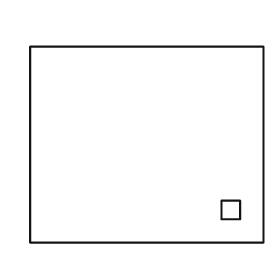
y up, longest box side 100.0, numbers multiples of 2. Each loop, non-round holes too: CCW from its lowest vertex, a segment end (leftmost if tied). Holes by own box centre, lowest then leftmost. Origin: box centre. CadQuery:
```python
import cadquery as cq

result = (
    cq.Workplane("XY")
    .moveTo(-50.0, -42.0)
    .lineTo(50.0, -42.0)
    .lineTo(50.0, 42.0)
    .lineTo(-50.0, 42.0)
    .close()
    .moveTo(32.0, -32.0)
    .lineTo(40.0, -32.0)
    .lineTo(40.0, -24.0)
    .lineTo(32.0, -24.0)
    .close()
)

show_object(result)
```